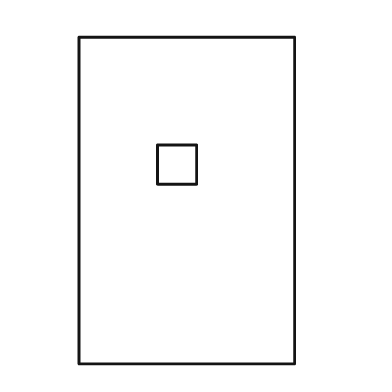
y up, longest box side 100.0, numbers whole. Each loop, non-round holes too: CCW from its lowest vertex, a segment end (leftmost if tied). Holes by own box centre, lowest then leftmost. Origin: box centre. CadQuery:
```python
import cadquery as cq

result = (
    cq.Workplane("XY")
    .moveTo(-33.0, -50.0)
    .lineTo(33.0, -50.0)
    .lineTo(33.0, 50.0)
    .lineTo(-33.0, 50.0)
    .close()
    .moveTo(-9.0, 5.0)
    .lineTo(3.0, 5.0)
    .lineTo(3.0, 17.0)
    .lineTo(-9.0, 17.0)
    .close()
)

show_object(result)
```